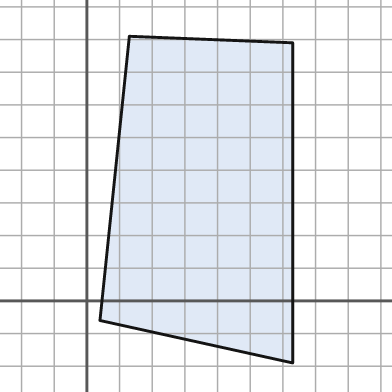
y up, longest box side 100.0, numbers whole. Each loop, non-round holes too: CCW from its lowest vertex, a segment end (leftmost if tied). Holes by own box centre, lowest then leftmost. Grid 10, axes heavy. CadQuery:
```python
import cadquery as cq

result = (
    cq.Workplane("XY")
    .moveTo(63.0, -19.0)
    .lineTo(63.0, 79.0)
    .lineTo(13.0, 81.0)
    .lineTo(4.0, -6.0)
    .close()
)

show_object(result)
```